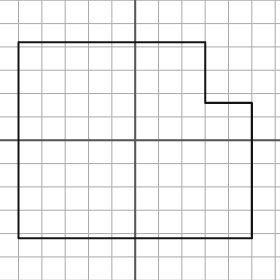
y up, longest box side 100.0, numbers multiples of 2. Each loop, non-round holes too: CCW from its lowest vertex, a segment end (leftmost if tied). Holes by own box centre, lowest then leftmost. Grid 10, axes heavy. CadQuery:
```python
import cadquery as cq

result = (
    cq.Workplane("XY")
    .moveTo(-50.0, -42.0)
    .lineTo(50.0, -42.0)
    .lineTo(50.0, 16.0)
    .lineTo(30.0, 16.0)
    .lineTo(30.0, 42.0)
    .lineTo(-50.0, 42.0)
    .close()
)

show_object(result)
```